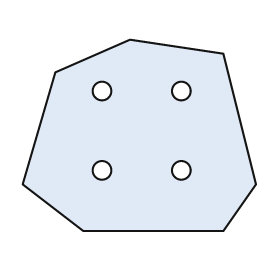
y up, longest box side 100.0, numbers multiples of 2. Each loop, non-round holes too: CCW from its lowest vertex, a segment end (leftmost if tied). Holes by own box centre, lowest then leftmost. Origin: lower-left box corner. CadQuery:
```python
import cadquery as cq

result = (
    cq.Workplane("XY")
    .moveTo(26.0, 0.0)
    .lineTo(86.0, 0.0)
    .lineTo(100.0, 20.0)
    .lineTo(86.0, 76.0)
    .lineTo(46.0, 82.0)
    .lineTo(14.0, 68.0)
    .lineTo(0.0, 20.0)
    .close()
    .moveTo(34.0, 26.0)
    .circle(4.0)
    .moveTo(68.0, 26.0)
    .circle(4.0)
    .moveTo(34.0, 60.0)
    .circle(4.0)
    .moveTo(68.0, 60.0)
    .circle(4.0)
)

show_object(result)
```